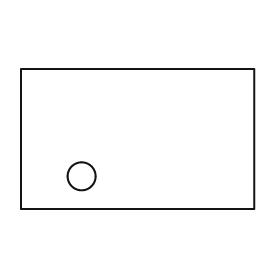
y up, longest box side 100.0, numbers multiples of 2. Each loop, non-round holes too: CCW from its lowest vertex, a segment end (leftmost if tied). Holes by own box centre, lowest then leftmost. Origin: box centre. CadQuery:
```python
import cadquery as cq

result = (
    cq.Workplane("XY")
    .moveTo(-50.0, -30.0)
    .lineTo(50.0, -30.0)
    .lineTo(50.0, 30.0)
    .lineTo(-50.0, 30.0)
    .close()
    .moveTo(-24.0, -16.0)
    .circle(6.0)
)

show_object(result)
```